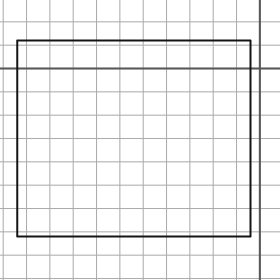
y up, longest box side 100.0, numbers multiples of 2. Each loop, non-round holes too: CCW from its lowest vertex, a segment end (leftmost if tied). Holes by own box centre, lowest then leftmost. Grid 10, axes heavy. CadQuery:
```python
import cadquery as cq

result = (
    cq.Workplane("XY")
    .moveTo(-104.0, -72.0)
    .lineTo(-4.0, -72.0)
    .lineTo(-4.0, 12.0)
    .lineTo(-104.0, 12.0)
    .close()
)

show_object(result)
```